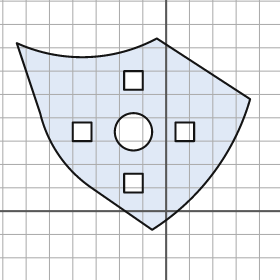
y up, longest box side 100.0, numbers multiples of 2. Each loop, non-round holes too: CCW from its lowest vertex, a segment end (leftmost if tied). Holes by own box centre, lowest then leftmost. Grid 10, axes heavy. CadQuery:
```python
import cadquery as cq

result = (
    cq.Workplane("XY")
    .moveTo(-6.0, -8.0)
    .threePointArc((20.0, 16.0), (36.0, 48.0))
    .lineTo(-4.0, 74.0)
    .threePointArc((-34.0, 66.0), (-64.0, 72.0))
    .lineTo(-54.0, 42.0)
    .threePointArc((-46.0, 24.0), (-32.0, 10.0))
    .close()
    .moveTo(-18.0, 8.0)
    .lineTo(-10.0, 8.0)
    .lineTo(-10.0, 16.0)
    .lineTo(-18.0, 16.0)
    .close()
    .moveTo(-40.0, 30.0)
    .lineTo(-32.0, 30.0)
    .lineTo(-32.0, 38.0)
    .lineTo(-40.0, 38.0)
    .close()
    .moveTo(-14.0, 34.0)
    .circle(8.0)
    .moveTo(4.0, 30.0)
    .lineTo(12.0, 30.0)
    .lineTo(12.0, 38.0)
    .lineTo(4.0, 38.0)
    .close()
    .moveTo(-18.0, 52.0)
    .lineTo(-10.0, 52.0)
    .lineTo(-10.0, 60.0)
    .lineTo(-18.0, 60.0)
    .close()
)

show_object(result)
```